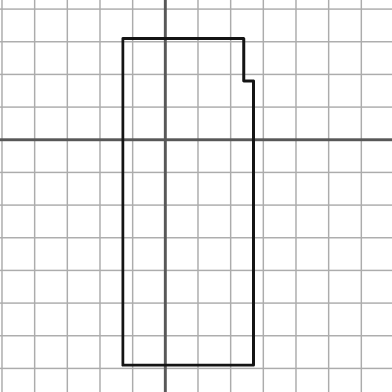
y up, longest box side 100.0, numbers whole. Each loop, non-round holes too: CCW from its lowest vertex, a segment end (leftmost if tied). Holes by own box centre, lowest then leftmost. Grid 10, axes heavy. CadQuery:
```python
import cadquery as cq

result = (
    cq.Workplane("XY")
    .moveTo(-13.0, -69.0)
    .lineTo(27.0, -69.0)
    .lineTo(27.0, 18.0)
    .lineTo(24.0, 18.0)
    .lineTo(24.0, 31.0)
    .lineTo(-13.0, 31.0)
    .close()
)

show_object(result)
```